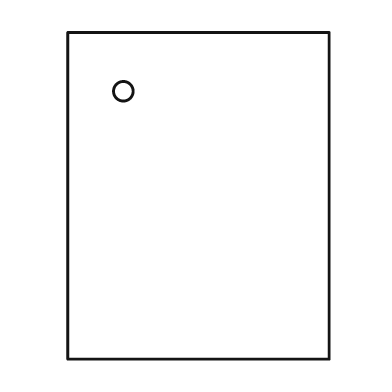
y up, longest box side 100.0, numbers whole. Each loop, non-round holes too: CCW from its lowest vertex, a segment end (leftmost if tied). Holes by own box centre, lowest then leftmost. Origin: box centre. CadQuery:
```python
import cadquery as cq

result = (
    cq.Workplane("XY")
    .moveTo(-40.0, -50.0)
    .lineTo(40.0, -50.0)
    .lineTo(40.0, 50.0)
    .lineTo(-40.0, 50.0)
    .close()
    .moveTo(-23.0, 32.0)
    .circle(3.0)
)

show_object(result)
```